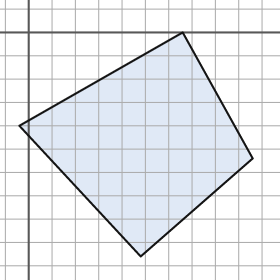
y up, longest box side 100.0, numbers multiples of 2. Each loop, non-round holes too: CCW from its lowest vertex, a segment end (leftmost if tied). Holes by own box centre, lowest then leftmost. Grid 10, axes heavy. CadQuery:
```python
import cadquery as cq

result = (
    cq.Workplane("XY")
    .moveTo(48.0, -96.0)
    .lineTo(96.0, -54.0)
    .lineTo(66.0, 0.0)
    .lineTo(-4.0, -40.0)
    .close()
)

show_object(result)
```